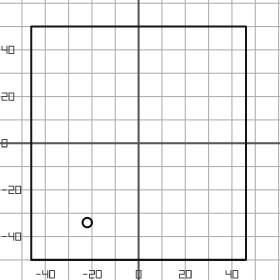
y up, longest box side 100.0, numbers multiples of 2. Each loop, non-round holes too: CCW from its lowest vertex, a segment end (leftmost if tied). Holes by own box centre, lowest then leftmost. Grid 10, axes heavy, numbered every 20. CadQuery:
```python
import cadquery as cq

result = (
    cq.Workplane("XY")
    .moveTo(-46.0, -50.0)
    .lineTo(46.0, -50.0)
    .lineTo(46.0, 50.0)
    .lineTo(-46.0, 50.0)
    .close()
    .moveTo(-22.0, -34.0)
    .circle(2.0)
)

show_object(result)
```